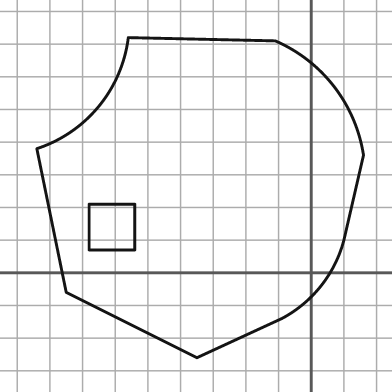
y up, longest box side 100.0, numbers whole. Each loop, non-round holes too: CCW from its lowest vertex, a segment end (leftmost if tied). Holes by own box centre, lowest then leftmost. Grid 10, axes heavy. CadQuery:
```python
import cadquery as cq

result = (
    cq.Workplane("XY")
    .moveTo(-35.0, -26.0)
    .lineTo(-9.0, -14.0)
    .threePointArc((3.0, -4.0), (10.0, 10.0))
    .lineTo(16.0, 36.0)
    .threePointArc((7.0, 57.0), (-11.0, 71.0))
    .lineTo(-56.0, 72.0)
    .threePointArc((-65.0, 51.0), (-84.0, 38.0))
    .lineTo(-75.0, -6.0)
    .close()
    .moveTo(-68.0, 7.0)
    .lineTo(-54.0, 7.0)
    .lineTo(-54.0, 21.0)
    .lineTo(-68.0, 21.0)
    .close()
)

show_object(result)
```